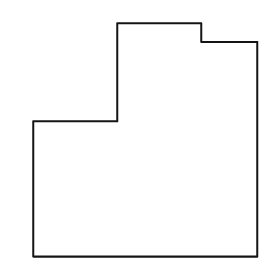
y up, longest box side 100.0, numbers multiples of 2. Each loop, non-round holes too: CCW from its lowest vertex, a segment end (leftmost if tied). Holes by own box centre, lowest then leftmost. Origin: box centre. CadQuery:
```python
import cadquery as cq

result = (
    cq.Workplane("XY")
    .moveTo(-48.0, -50.0)
    .lineTo(48.0, -50.0)
    .lineTo(48.0, 42.0)
    .lineTo(24.0, 42.0)
    .lineTo(24.0, 50.0)
    .lineTo(-12.0, 50.0)
    .lineTo(-12.0, 8.0)
    .lineTo(-48.0, 8.0)
    .close()
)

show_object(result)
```